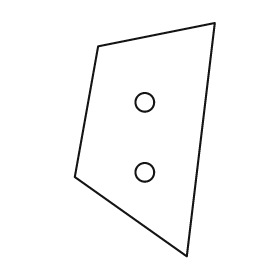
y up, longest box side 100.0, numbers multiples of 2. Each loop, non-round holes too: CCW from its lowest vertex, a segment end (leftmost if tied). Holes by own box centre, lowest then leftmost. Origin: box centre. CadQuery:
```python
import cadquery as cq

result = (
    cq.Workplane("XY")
    .moveTo(18.0, -50.0)
    .lineTo(30.0, 50.0)
    .lineTo(-20.0, 40.0)
    .lineTo(-30.0, -16.0)
    .close()
    .moveTo(0.0, -14.0)
    .circle(4.0)
    .moveTo(0.0, 16.0)
    .circle(4.0)
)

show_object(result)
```